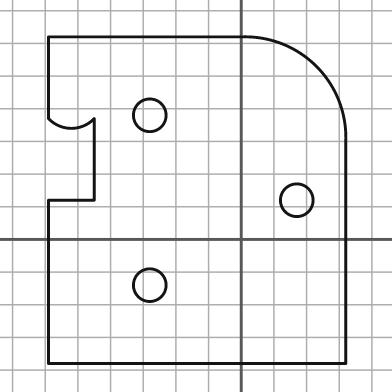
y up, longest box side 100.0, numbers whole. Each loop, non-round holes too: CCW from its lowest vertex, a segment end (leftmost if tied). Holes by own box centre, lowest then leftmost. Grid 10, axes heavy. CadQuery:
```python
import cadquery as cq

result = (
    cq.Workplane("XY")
    .moveTo(-59.0, -38.0)
    .lineTo(32.0, -38.0)
    .lineTo(32.0, 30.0)
    .threePointArc((23.0, 53.0), (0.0, 62.0))
    .lineTo(-59.0, 62.0)
    .lineTo(-59.0, 37.0)
    .threePointArc((-52.0, 34.0), (-45.0, 37.0))
    .lineTo(-45.0, 12.0)
    .lineTo(-59.0, 12.0)
    .close()
    .moveTo(-28.0, -14.0)
    .circle(5.0)
    .moveTo(17.0, 12.0)
    .circle(5.0)
    .moveTo(-28.0, 38.0)
    .circle(5.0)
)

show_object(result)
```